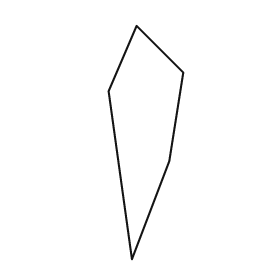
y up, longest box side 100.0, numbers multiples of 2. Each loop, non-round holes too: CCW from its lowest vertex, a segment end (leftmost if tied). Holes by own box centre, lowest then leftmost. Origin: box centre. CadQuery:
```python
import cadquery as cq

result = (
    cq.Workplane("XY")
    .moveTo(-6.0, -50.0)
    .lineTo(10.0, -8.0)
    .lineTo(16.0, 30.0)
    .lineTo(-4.0, 50.0)
    .lineTo(-16.0, 22.0)
    .close()
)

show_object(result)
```